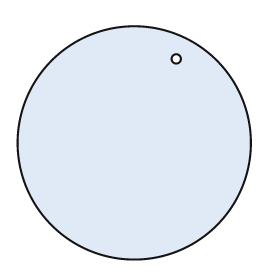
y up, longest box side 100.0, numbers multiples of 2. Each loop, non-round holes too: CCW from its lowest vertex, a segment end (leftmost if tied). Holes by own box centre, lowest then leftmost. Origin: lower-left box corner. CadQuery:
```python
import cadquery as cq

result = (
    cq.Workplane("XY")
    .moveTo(50.0, 50.0)
    .circle(50.0)
    .moveTo(68.0, 86.0)
    .circle(2.0)
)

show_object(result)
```